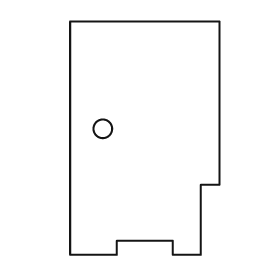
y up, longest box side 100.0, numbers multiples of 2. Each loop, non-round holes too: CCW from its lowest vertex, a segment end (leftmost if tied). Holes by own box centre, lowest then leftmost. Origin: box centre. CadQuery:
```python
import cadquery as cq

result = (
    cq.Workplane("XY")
    .moveTo(-32.0, -50.0)
    .lineTo(-12.0, -50.0)
    .lineTo(-12.0, -44.0)
    .lineTo(12.0, -44.0)
    .lineTo(12.0, -50.0)
    .lineTo(24.0, -50.0)
    .lineTo(24.0, -20.0)
    .lineTo(32.0, -20.0)
    .lineTo(32.0, 50.0)
    .lineTo(-32.0, 50.0)
    .close()
    .moveTo(-18.0, 4.0)
    .circle(4.0)
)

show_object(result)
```